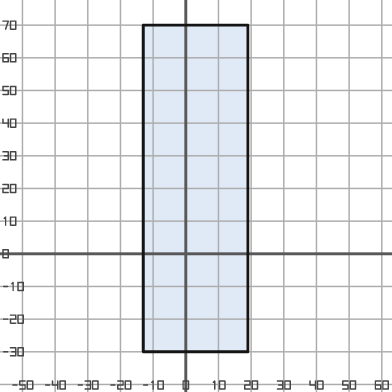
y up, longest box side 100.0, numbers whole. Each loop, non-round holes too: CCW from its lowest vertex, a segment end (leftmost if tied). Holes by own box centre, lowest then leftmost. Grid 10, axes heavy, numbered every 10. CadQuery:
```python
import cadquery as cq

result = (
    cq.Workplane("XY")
    .moveTo(-13.0, -30.0)
    .lineTo(19.0, -30.0)
    .lineTo(19.0, 70.0)
    .lineTo(-13.0, 70.0)
    .close()
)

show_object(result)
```